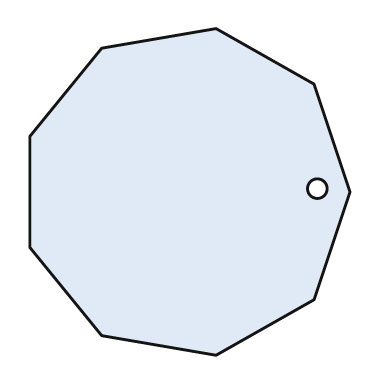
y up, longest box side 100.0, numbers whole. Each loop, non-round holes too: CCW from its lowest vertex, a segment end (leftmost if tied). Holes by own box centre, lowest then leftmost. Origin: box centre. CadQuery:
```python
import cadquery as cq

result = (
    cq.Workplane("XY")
    .moveTo(8.0, -50.0)
    .lineTo(38.0, -33.0)
    .lineTo(49.0, 0.0)
    .lineTo(38.0, 33.0)
    .lineTo(8.0, 50.0)
    .lineTo(-27.0, 44.0)
    .lineTo(-49.0, 17.0)
    .lineTo(-49.0, -17.0)
    .lineTo(-27.0, -44.0)
    .close()
    .moveTo(39.0, 1.0)
    .circle(3.0)
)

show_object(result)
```